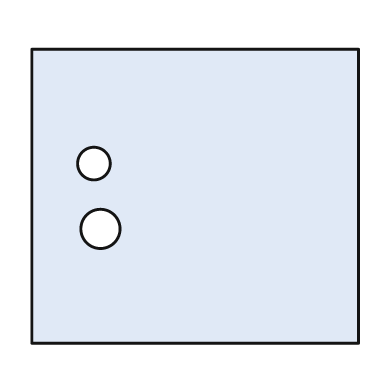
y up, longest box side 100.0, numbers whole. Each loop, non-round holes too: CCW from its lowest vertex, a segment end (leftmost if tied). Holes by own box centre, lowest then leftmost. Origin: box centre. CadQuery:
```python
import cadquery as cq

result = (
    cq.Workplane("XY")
    .moveTo(-50.0, -45.0)
    .lineTo(50.0, -45.0)
    .lineTo(50.0, 45.0)
    .lineTo(-50.0, 45.0)
    .close()
    .moveTo(-29.0, -10.0)
    .circle(6.0)
    .moveTo(-31.0, 10.0)
    .circle(5.0)
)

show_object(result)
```